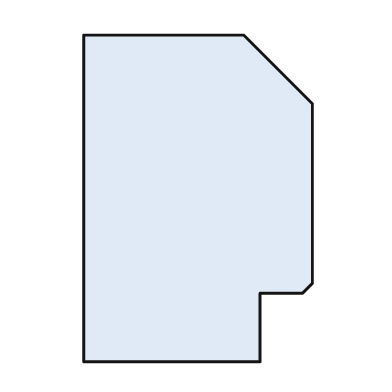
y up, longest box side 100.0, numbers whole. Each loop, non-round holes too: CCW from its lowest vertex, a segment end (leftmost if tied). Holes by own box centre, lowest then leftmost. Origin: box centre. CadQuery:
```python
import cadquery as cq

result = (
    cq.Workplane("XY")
    .moveTo(-35.0, -50.0)
    .lineTo(19.0, -50.0)
    .lineTo(19.0, -29.0)
    .lineTo(32.0, -29.0)
    .lineTo(35.0, -26.0)
    .lineTo(35.0, 29.0)
    .lineTo(14.0, 50.0)
    .lineTo(-35.0, 50.0)
    .close()
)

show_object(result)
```